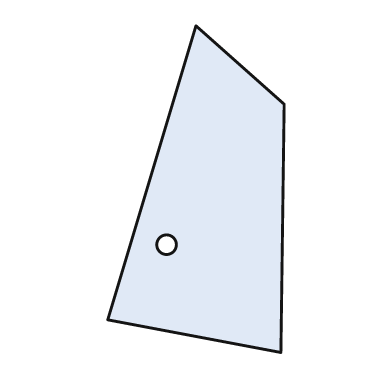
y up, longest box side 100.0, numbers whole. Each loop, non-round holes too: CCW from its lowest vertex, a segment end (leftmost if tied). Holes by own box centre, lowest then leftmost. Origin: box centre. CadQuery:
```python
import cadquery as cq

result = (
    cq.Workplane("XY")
    .moveTo(26.0, -50.0)
    .lineTo(27.0, 26.0)
    .lineTo(0.0, 50.0)
    .lineTo(-27.0, -40.0)
    .close()
    .moveTo(-9.0, -17.0)
    .circle(3.0)
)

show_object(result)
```